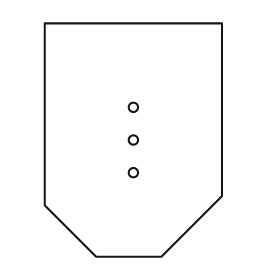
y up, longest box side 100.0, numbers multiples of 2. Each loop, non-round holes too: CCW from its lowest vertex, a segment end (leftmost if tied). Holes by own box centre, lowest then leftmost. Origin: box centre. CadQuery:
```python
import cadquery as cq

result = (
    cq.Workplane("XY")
    .moveTo(-16.0, -50.0)
    .lineTo(12.0, -50.0)
    .lineTo(38.0, -24.0)
    .lineTo(38.0, 50.0)
    .lineTo(-38.0, 50.0)
    .lineTo(-38.0, -28.0)
    .close()
    .moveTo(0.0, -14.0)
    .circle(2.0)
    .moveTo(0.0, 0.0)
    .circle(2.0)
    .moveTo(0.0, 14.0)
    .circle(2.0)
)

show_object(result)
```